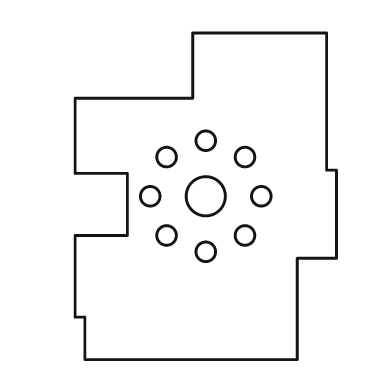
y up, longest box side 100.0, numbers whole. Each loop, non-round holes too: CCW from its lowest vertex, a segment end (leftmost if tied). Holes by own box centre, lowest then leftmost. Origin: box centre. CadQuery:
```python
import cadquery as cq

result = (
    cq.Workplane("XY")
    .moveTo(-37.0, -50.0)
    .lineTo(28.0, -50.0)
    .lineTo(28.0, -19.0)
    .lineTo(40.0, -19.0)
    .lineTo(40.0, 8.0)
    .lineTo(37.0, 8.0)
    .lineTo(37.0, 50.0)
    .lineTo(-4.0, 50.0)
    .lineTo(-4.0, 30.0)
    .lineTo(-40.0, 30.0)
    .lineTo(-40.0, 7.0)
    .lineTo(-24.0, 7.0)
    .lineTo(-24.0, -12.0)
    .lineTo(-40.0, -12.0)
    .lineTo(-40.0, -37.0)
    .lineTo(-37.0, -37.0)
    .close()
    .moveTo(0.0, -17.0)
    .circle(3.0)
    .moveTo(-12.0, -12.0)
    .circle(3.0)
    .moveTo(12.0, -12.0)
    .circle(3.0)
    .moveTo(-17.0, 0.0)
    .circle(3.0)
    .moveTo(0.0, 0.0)
    .circle(6.0)
    .moveTo(17.0, 0.0)
    .circle(3.0)
    .moveTo(-12.0, 12.0)
    .circle(3.0)
    .moveTo(12.0, 12.0)
    .circle(3.0)
    .moveTo(0.0, 17.0)
    .circle(3.0)
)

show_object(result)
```